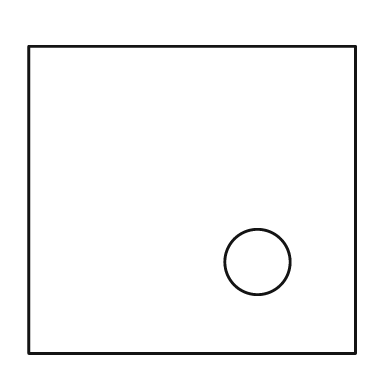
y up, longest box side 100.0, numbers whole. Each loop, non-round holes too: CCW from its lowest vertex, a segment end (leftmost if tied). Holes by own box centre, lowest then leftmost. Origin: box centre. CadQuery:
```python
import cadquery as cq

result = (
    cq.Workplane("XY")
    .moveTo(-50.0, -47.0)
    .lineTo(50.0, -47.0)
    .lineTo(50.0, 47.0)
    .lineTo(-50.0, 47.0)
    .close()
    .moveTo(20.0, -19.0)
    .circle(10.0)
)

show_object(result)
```